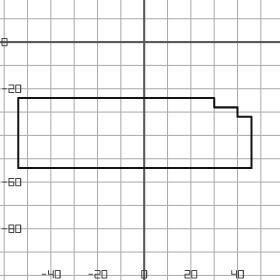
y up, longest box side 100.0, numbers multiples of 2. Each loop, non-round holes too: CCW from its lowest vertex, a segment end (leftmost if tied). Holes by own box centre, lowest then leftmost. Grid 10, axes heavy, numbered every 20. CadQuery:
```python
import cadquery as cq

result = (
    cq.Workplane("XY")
    .moveTo(-54.0, -54.0)
    .lineTo(46.0, -54.0)
    .lineTo(46.0, -32.0)
    .lineTo(40.0, -32.0)
    .lineTo(40.0, -28.0)
    .lineTo(30.0, -28.0)
    .lineTo(30.0, -24.0)
    .lineTo(-54.0, -24.0)
    .close()
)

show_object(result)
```